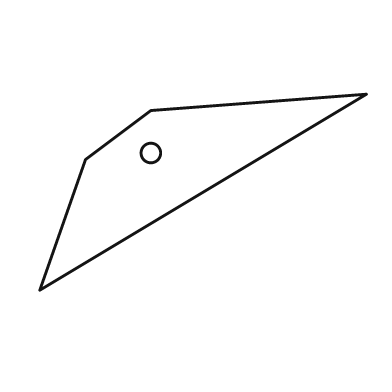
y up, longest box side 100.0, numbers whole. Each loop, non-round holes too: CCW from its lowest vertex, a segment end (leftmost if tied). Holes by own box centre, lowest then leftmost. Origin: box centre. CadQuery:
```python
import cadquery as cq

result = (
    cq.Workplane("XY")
    .moveTo(-50.0, -30.0)
    .lineTo(50.0, 30.0)
    .lineTo(-16.0, 25.0)
    .lineTo(-36.0, 10.0)
    .close()
    .moveTo(-16.0, 12.0)
    .circle(3.0)
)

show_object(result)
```